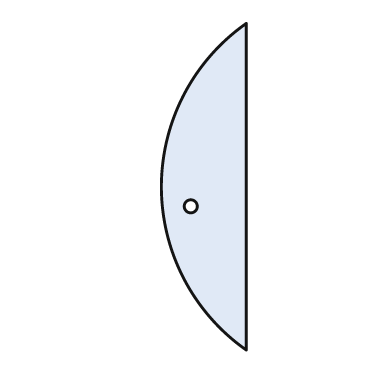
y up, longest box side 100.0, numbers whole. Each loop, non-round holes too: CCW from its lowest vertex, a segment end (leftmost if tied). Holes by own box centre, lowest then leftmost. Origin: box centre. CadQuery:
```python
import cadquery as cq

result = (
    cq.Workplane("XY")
    .moveTo(13.0, -50.0)
    .lineTo(13.0, 50.0)
    .threePointArc((-13.0, 0.0), (13.0, -50.0))
    .close()
    .moveTo(-4.0, -6.0)
    .circle(2.0)
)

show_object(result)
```